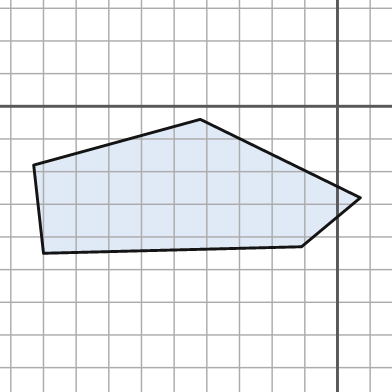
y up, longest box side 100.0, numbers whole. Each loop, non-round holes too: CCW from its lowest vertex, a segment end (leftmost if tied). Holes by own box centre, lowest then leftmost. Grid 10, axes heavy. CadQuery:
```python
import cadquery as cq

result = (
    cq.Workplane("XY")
    .moveTo(-90.0, -45.0)
    .lineTo(-11.0, -43.0)
    .lineTo(7.0, -28.0)
    .lineTo(-42.0, -4.0)
    .lineTo(-93.0, -18.0)
    .close()
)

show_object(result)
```